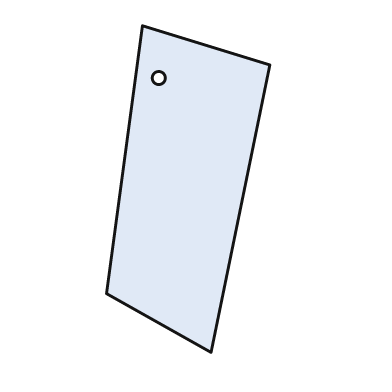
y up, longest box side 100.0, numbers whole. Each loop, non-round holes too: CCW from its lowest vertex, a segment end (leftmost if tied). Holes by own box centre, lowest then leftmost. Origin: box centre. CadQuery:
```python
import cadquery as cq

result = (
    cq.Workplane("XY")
    .moveTo(7.0, -50.0)
    .lineTo(25.0, 38.0)
    .lineTo(-14.0, 50.0)
    .lineTo(-25.0, -32.0)
    .close()
    .moveTo(-9.0, 34.0)
    .circle(2.0)
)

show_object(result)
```